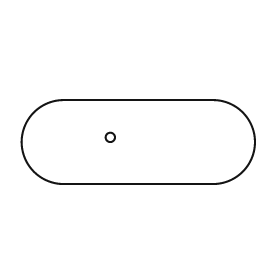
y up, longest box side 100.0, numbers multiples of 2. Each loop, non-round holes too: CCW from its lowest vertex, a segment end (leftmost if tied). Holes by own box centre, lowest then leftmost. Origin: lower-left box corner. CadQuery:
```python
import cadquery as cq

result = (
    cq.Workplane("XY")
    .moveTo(18.0, 0.0)
    .lineTo(82.0, 0.0)
    .threePointArc((100.0, 18.0), (82.0, 36.0))
    .lineTo(18.0, 36.0)
    .threePointArc((0.0, 18.0), (18.0, 0.0))
    .close()
    .moveTo(38.0, 20.0)
    .circle(2.0)
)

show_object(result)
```